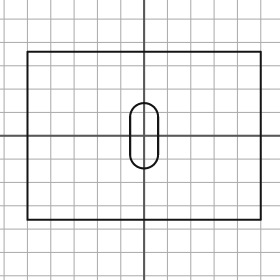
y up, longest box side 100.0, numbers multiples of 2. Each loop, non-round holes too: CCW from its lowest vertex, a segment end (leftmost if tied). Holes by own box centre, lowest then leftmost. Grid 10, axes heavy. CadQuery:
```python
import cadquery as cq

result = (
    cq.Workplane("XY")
    .moveTo(-50.0, -36.0)
    .lineTo(50.0, -36.0)
    .lineTo(50.0, 36.0)
    .lineTo(-50.0, 36.0)
    .close()
    .moveTo(-6.0, -8.0)
    .threePointArc((0.0, -14.0), (6.0, -8.0))
    .lineTo(6.0, 8.0)
    .threePointArc((0.0, 14.0), (-6.0, 8.0))
    .close()
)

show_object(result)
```